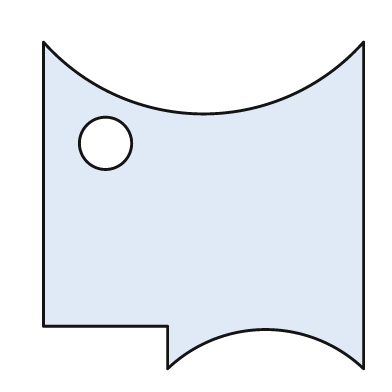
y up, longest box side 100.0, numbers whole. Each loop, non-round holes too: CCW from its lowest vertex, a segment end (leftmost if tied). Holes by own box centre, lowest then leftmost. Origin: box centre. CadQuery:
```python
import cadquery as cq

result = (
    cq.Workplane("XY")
    .moveTo(-11.0, -50.0)
    .threePointArc((19.0, -38.0), (49.0, -50.0))
    .lineTo(49.0, 50.0)
    .threePointArc((0.0, 28.0), (-49.0, 50.0))
    .lineTo(-49.0, -37.0)
    .lineTo(-11.0, -37.0)
    .close()
    .moveTo(-30.0, 19.0)
    .circle(8.0)
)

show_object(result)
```